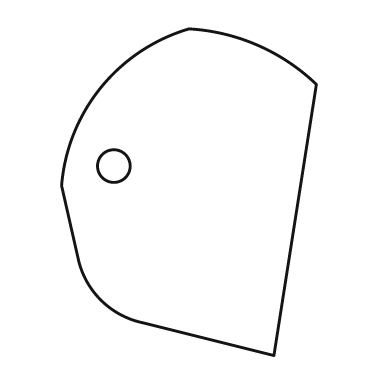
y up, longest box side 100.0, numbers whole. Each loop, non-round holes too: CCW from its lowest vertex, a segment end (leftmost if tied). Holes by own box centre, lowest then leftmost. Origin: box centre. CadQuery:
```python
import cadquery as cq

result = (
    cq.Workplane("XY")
    .moveTo(26.0, -50.0)
    .lineTo(39.0, 33.0)
    .threePointArc((21.0, 45.0), (0.0, 50.0))
    .threePointArc((-27.0, 32.0), (-39.0, 2.0))
    .lineTo(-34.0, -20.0)
    .threePointArc((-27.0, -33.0), (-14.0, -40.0))
    .close()
    .moveTo(-23.0, 8.0)
    .circle(5.0)
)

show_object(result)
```